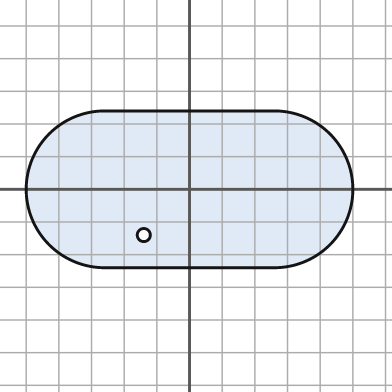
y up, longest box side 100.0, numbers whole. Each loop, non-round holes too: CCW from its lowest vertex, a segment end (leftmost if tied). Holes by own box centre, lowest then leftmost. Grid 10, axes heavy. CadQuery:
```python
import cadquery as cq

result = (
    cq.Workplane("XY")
    .moveTo(-26.0, -24.0)
    .lineTo(26.0, -24.0)
    .threePointArc((50.0, 0.0), (26.0, 24.0))
    .lineTo(-26.0, 24.0)
    .threePointArc((-50.0, 0.0), (-26.0, -24.0))
    .close()
    .moveTo(-14.0, -14.0)
    .circle(2.0)
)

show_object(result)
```